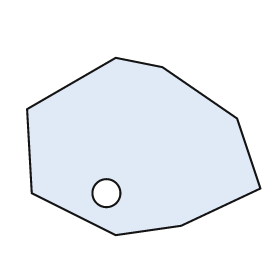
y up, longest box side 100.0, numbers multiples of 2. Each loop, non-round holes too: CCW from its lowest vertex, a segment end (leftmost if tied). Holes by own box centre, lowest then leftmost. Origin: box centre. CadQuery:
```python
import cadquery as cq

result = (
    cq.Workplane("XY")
    .moveTo(-12.0, -38.0)
    .lineTo(16.0, -34.0)
    .lineTo(50.0, -18.0)
    .lineTo(40.0, 12.0)
    .lineTo(8.0, 34.0)
    .lineTo(-12.0, 38.0)
    .lineTo(-50.0, 16.0)
    .lineTo(-48.0, -20.0)
    .close()
    .moveTo(-16.0, -20.0)
    .circle(6.0)
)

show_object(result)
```